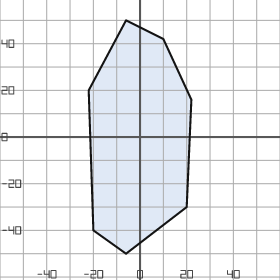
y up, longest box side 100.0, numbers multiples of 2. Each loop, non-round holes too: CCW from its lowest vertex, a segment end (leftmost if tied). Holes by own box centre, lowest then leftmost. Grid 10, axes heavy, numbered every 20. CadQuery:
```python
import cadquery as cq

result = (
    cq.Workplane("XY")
    .moveTo(-6.0, -50.0)
    .lineTo(20.0, -30.0)
    .lineTo(22.0, 16.0)
    .lineTo(10.0, 42.0)
    .lineTo(-6.0, 50.0)
    .lineTo(-22.0, 20.0)
    .lineTo(-20.0, -40.0)
    .close()
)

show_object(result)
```